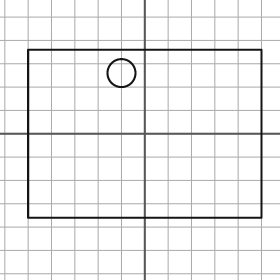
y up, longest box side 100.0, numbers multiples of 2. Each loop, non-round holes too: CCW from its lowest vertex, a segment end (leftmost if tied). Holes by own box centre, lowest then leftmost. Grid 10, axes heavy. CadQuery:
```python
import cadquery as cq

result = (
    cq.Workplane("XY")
    .moveTo(-50.0, -36.0)
    .lineTo(50.0, -36.0)
    .lineTo(50.0, 36.0)
    .lineTo(-50.0, 36.0)
    .close()
    .moveTo(-10.0, 26.0)
    .circle(6.0)
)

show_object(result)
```